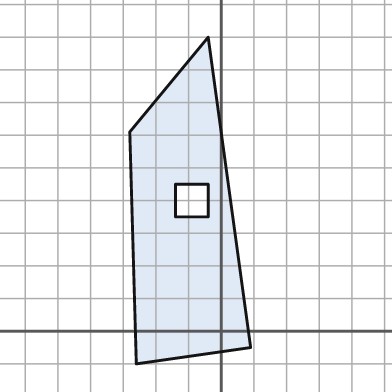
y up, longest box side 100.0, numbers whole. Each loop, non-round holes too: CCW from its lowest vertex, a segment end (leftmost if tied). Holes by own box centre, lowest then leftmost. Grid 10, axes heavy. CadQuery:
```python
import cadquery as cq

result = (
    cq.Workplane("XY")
    .moveTo(-26.0, -10.0)
    .lineTo(9.0, -5.0)
    .lineTo(-4.0, 90.0)
    .lineTo(-28.0, 61.0)
    .close()
    .moveTo(-14.0, 35.0)
    .lineTo(-4.0, 35.0)
    .lineTo(-4.0, 45.0)
    .lineTo(-14.0, 45.0)
    .close()
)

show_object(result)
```